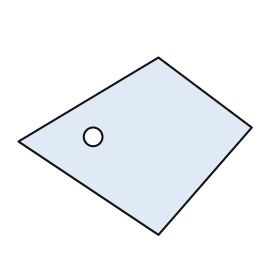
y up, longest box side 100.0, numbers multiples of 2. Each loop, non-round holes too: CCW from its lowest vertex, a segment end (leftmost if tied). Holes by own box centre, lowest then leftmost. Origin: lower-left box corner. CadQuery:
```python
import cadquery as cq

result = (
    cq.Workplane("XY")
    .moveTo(60.0, 0.0)
    .lineTo(100.0, 46.0)
    .lineTo(60.0, 76.0)
    .lineTo(0.0, 40.0)
    .close()
    .moveTo(32.0, 42.0)
    .circle(4.0)
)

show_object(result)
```